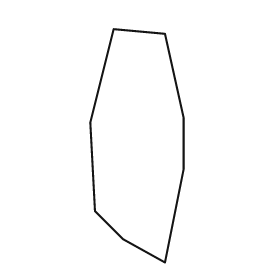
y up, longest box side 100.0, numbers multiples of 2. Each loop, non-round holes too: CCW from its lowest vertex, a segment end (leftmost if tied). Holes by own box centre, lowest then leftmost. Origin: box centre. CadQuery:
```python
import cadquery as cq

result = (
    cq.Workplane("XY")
    .moveTo(12.0, -50.0)
    .lineTo(20.0, -10.0)
    .lineTo(20.0, 12.0)
    .lineTo(12.0, 48.0)
    .lineTo(-10.0, 50.0)
    .lineTo(-20.0, 10.0)
    .lineTo(-18.0, -28.0)
    .lineTo(-6.0, -40.0)
    .close()
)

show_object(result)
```